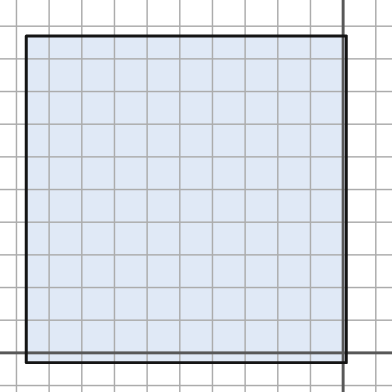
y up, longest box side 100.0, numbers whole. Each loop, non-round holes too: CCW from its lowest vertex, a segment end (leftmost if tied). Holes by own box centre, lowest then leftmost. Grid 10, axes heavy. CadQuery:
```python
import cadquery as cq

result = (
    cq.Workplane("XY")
    .moveTo(-97.0, -3.0)
    .lineTo(1.0, -3.0)
    .lineTo(1.0, 97.0)
    .lineTo(-97.0, 97.0)
    .close()
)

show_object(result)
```